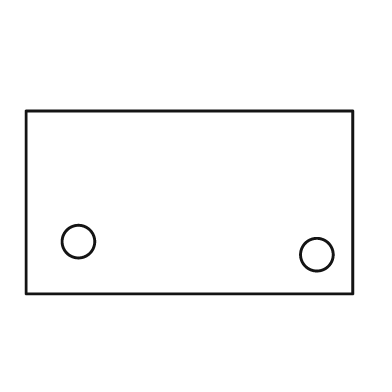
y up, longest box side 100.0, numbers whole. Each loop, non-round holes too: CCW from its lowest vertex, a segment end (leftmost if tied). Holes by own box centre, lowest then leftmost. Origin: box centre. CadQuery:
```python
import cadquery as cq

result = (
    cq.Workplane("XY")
    .moveTo(-50.0, -28.0)
    .lineTo(50.0, -28.0)
    .lineTo(50.0, 28.0)
    .lineTo(-50.0, 28.0)
    .close()
    .moveTo(39.0, -16.0)
    .circle(5.0)
    .moveTo(-34.0, -12.0)
    .circle(5.0)
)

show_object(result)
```